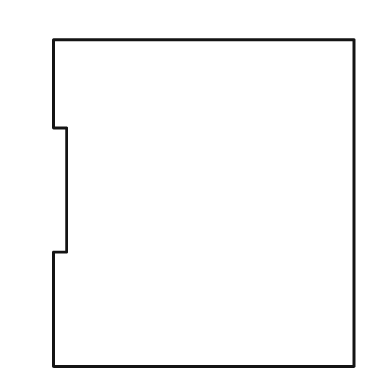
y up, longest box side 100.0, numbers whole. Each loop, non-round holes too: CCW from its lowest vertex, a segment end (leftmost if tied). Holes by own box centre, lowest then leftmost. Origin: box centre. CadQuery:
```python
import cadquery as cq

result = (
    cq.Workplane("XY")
    .moveTo(-46.0, -50.0)
    .lineTo(46.0, -50.0)
    .lineTo(46.0, 50.0)
    .lineTo(-46.0, 50.0)
    .lineTo(-46.0, 23.0)
    .lineTo(-42.0, 23.0)
    .lineTo(-42.0, -15.0)
    .lineTo(-46.0, -15.0)
    .close()
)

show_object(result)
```